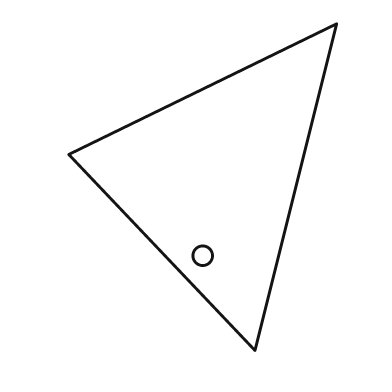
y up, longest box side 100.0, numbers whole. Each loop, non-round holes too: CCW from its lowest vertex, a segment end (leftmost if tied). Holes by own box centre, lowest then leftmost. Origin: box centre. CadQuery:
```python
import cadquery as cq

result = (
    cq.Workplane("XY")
    .moveTo(16.0, -50.0)
    .lineTo(41.0, 50.0)
    .lineTo(-41.0, 10.0)
    .close()
    .moveTo(0.0, -21.0)
    .circle(3.0)
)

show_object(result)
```